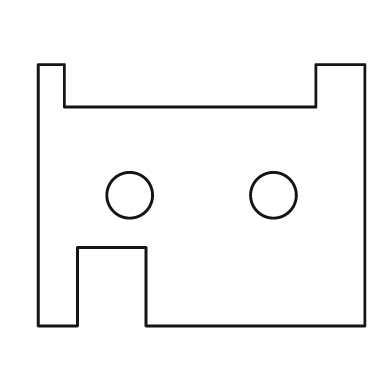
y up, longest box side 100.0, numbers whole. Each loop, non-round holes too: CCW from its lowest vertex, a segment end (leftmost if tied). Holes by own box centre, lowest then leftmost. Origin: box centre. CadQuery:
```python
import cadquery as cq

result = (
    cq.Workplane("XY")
    .moveTo(-50.0, -40.0)
    .lineTo(-38.0, -40.0)
    .lineTo(-38.0, -16.0)
    .lineTo(-17.0, -16.0)
    .lineTo(-17.0, -40.0)
    .lineTo(50.0, -40.0)
    .lineTo(50.0, 40.0)
    .lineTo(35.0, 40.0)
    .lineTo(35.0, 27.0)
    .lineTo(-42.0, 27.0)
    .lineTo(-42.0, 40.0)
    .lineTo(-50.0, 40.0)
    .close()
    .moveTo(-22.0, 0.0)
    .circle(7.0)
    .moveTo(22.0, 0.0)
    .circle(7.0)
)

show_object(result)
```